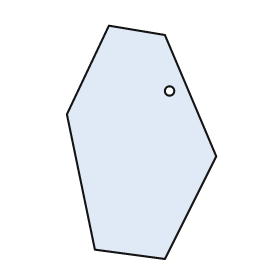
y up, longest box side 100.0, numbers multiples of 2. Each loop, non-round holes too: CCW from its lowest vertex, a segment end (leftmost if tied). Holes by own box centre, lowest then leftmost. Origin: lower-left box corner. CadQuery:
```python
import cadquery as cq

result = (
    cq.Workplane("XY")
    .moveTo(42.0, 0.0)
    .lineTo(64.0, 44.0)
    .lineTo(42.0, 96.0)
    .lineTo(18.0, 100.0)
    .lineTo(0.0, 62.0)
    .lineTo(12.0, 4.0)
    .close()
    .moveTo(44.0, 72.0)
    .circle(2.0)
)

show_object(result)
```